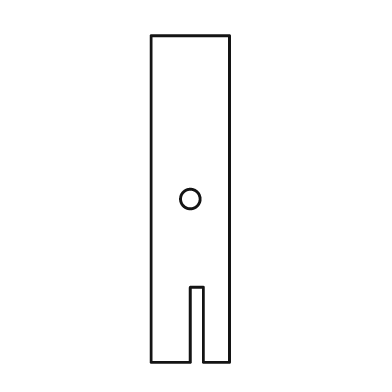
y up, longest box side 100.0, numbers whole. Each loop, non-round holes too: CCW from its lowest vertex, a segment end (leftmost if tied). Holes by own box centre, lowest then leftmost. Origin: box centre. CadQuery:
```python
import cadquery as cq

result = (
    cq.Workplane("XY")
    .moveTo(-12.0, -50.0)
    .lineTo(0.0, -50.0)
    .lineTo(0.0, -27.0)
    .lineTo(4.0, -27.0)
    .lineTo(4.0, -50.0)
    .lineTo(12.0, -50.0)
    .lineTo(12.0, 50.0)
    .lineTo(-12.0, 50.0)
    .close()
    .moveTo(0.0, 0.0)
    .circle(3.0)
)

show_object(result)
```